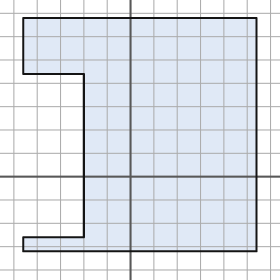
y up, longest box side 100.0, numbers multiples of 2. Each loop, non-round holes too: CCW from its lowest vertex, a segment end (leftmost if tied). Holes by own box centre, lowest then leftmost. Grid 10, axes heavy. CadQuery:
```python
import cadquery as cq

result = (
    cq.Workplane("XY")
    .moveTo(-46.0, -32.0)
    .lineTo(54.0, -32.0)
    .lineTo(54.0, 68.0)
    .lineTo(-46.0, 68.0)
    .lineTo(-46.0, 44.0)
    .lineTo(-20.0, 44.0)
    .lineTo(-20.0, -26.0)
    .lineTo(-46.0, -26.0)
    .close()
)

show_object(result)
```